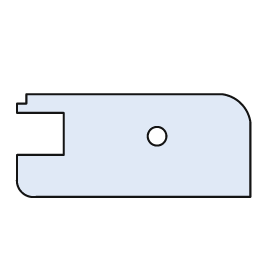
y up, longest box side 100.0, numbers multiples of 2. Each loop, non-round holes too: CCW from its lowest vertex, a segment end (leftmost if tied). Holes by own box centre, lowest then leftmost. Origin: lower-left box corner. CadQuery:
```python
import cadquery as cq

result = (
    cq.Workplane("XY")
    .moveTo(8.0, 0.0)
    .lineTo(100.0, 0.0)
    .lineTo(100.0, 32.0)
    .threePointArc((96.0, 40.0), (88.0, 44.0))
    .lineTo(4.0, 44.0)
    .lineTo(4.0, 40.0)
    .lineTo(0.0, 40.0)
    .lineTo(0.0, 36.0)
    .lineTo(20.0, 36.0)
    .lineTo(20.0, 18.0)
    .lineTo(0.0, 18.0)
    .lineTo(0.0, 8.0)
    .threePointArc((2.0, 2.0), (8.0, 0.0))
    .close()
    .moveTo(60.0, 26.0)
    .circle(4.0)
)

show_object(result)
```